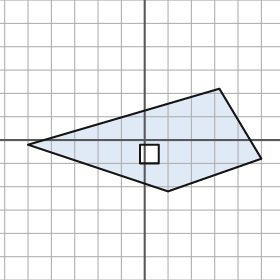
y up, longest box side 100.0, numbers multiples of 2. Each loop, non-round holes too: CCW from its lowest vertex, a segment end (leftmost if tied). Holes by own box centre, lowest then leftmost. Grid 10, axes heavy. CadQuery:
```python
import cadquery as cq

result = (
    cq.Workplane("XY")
    .moveTo(10.0, -22.0)
    .lineTo(50.0, -8.0)
    .lineTo(32.0, 22.0)
    .lineTo(-50.0, -2.0)
    .close()
    .moveTo(-2.0, -10.0)
    .lineTo(6.0, -10.0)
    .lineTo(6.0, -2.0)
    .lineTo(-2.0, -2.0)
    .close()
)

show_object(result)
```